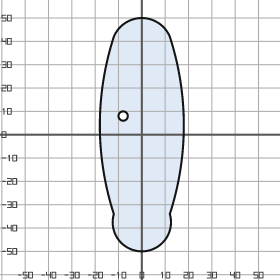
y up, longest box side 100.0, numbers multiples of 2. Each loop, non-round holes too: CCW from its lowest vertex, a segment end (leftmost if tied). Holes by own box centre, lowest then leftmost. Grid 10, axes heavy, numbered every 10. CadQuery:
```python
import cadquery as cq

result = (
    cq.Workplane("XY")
    .moveTo(-12.0, -34.0)
    .threePointArc((0.0, -50.0), (12.0, -34.0))
    .threePointArc((18.0, 4.0), (12.0, 42.0))
    .threePointArc((0.0, 50.0), (-12.0, 42.0))
    .threePointArc((-18.0, 4.0), (-12.0, -34.0))
    .close()
    .moveTo(-8.0, 8.0)
    .circle(2.0)
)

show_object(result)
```